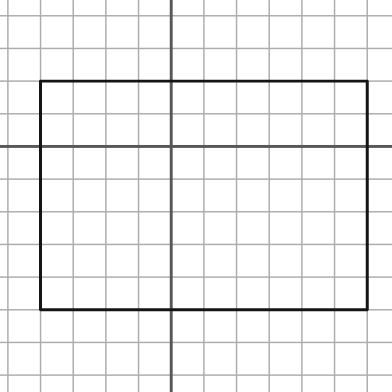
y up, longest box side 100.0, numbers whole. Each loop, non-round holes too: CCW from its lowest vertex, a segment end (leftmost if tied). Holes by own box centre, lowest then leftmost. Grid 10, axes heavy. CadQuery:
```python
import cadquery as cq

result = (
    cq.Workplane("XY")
    .moveTo(-40.0, -50.0)
    .lineTo(60.0, -50.0)
    .lineTo(60.0, 20.0)
    .lineTo(-40.0, 20.0)
    .close()
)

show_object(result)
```